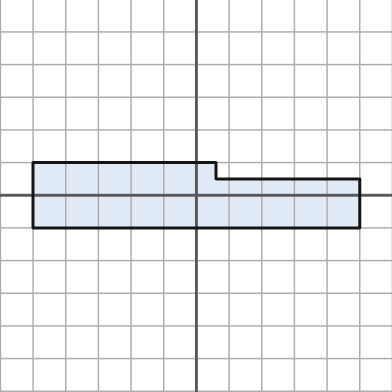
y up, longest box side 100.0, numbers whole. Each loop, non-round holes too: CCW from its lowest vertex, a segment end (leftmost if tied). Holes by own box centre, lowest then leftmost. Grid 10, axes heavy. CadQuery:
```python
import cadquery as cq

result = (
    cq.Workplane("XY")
    .moveTo(-50.0, -10.0)
    .lineTo(50.0, -10.0)
    .lineTo(50.0, 5.0)
    .lineTo(6.0, 5.0)
    .lineTo(6.0, 10.0)
    .lineTo(-50.0, 10.0)
    .close()
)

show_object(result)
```